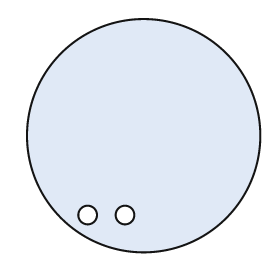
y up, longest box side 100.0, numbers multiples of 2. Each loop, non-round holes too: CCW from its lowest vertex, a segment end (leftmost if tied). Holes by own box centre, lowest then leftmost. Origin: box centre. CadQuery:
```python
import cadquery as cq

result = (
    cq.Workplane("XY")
    .moveTo(0.0, 0.0)
    .circle(50.0)
    .moveTo(-24.0, -34.0)
    .circle(4.0)
    .moveTo(-8.0, -34.0)
    .circle(4.0)
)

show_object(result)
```